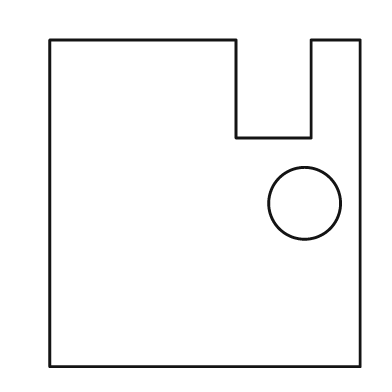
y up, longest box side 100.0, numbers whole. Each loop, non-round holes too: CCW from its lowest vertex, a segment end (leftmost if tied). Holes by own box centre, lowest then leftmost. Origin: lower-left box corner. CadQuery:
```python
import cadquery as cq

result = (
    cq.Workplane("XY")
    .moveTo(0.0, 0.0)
    .lineTo(95.0, 0.0)
    .lineTo(95.0, 100.0)
    .lineTo(80.0, 100.0)
    .lineTo(80.0, 70.0)
    .lineTo(57.0, 70.0)
    .lineTo(57.0, 100.0)
    .lineTo(0.0, 100.0)
    .close()
    .moveTo(78.0, 50.0)
    .circle(11.0)
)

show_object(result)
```